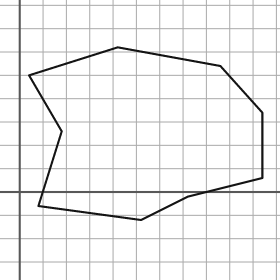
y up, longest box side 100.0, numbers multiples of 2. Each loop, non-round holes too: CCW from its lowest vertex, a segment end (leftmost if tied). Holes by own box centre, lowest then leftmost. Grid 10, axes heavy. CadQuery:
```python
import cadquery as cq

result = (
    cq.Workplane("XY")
    .moveTo(52.0, -12.0)
    .lineTo(72.0, -2.0)
    .lineTo(104.0, 6.0)
    .lineTo(104.0, 34.0)
    .lineTo(86.0, 54.0)
    .lineTo(42.0, 62.0)
    .lineTo(4.0, 50.0)
    .lineTo(18.0, 26.0)
    .lineTo(8.0, -6.0)
    .close()
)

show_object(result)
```